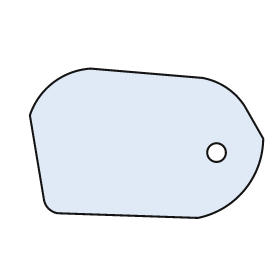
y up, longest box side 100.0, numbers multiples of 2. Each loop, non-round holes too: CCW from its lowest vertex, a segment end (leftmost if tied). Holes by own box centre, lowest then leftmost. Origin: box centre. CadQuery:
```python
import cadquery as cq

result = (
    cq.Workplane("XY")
    .moveTo(22.0, -32.0)
    .threePointArc((42.0, -20.0), (50.0, 2.0))
    .lineTo(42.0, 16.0)
    .threePointArc((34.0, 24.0), (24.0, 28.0))
    .lineTo(-24.0, 32.0)
    .threePointArc((-40.0, 26.0), (-50.0, 12.0))
    .lineTo(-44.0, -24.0)
    .threePointArc((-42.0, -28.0), (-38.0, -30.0))
    .close()
    .moveTo(30.0, -4.0)
    .circle(4.0)
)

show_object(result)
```